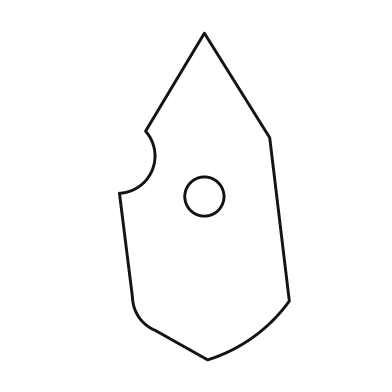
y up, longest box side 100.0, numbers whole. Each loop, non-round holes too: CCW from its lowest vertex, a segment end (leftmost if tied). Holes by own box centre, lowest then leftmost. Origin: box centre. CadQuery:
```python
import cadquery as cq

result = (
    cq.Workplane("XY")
    .moveTo(1.0, -50.0)
    .threePointArc((15.0, -43.0), (26.0, -32.0))
    .lineTo(20.0, 18.0)
    .lineTo(0.0, 50.0)
    .lineTo(-18.0, 20.0)
    .threePointArc((-16.0, 8.0), (-26.0, 1.0))
    .lineTo(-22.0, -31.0)
    .threePointArc((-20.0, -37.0), (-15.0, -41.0))
    .close()
    .moveTo(0.0, 0.0)
    .circle(6.0)
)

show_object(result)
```